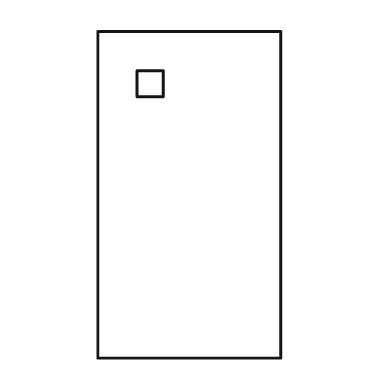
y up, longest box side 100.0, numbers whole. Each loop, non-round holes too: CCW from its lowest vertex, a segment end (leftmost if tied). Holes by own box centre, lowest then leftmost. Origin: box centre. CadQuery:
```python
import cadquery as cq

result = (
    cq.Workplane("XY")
    .moveTo(-28.0, -50.0)
    .lineTo(28.0, -50.0)
    .lineTo(28.0, 50.0)
    .lineTo(-28.0, 50.0)
    .close()
    .moveTo(-16.0, 30.0)
    .lineTo(-8.0, 30.0)
    .lineTo(-8.0, 38.0)
    .lineTo(-16.0, 38.0)
    .close()
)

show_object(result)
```